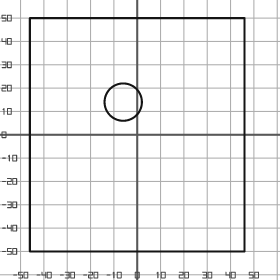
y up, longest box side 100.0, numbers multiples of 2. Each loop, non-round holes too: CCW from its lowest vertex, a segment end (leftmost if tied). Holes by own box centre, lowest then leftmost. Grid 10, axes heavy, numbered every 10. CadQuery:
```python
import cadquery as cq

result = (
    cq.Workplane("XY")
    .moveTo(-46.0, -50.0)
    .lineTo(46.0, -50.0)
    .lineTo(46.0, 50.0)
    .lineTo(-46.0, 50.0)
    .close()
    .moveTo(-6.0, 14.0)
    .circle(8.0)
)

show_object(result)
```